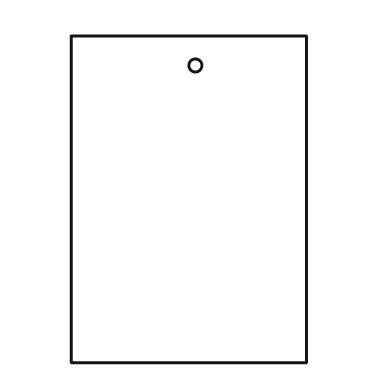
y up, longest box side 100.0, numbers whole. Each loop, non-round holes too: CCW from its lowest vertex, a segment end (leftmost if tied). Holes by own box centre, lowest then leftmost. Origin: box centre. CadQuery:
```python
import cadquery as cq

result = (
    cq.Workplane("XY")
    .moveTo(-36.0, -50.0)
    .lineTo(36.0, -50.0)
    .lineTo(36.0, 50.0)
    .lineTo(-36.0, 50.0)
    .close()
    .moveTo(2.0, 41.0)
    .circle(2.0)
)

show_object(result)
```